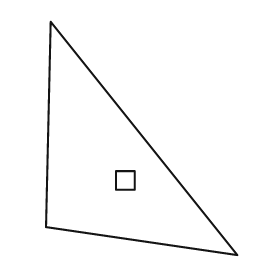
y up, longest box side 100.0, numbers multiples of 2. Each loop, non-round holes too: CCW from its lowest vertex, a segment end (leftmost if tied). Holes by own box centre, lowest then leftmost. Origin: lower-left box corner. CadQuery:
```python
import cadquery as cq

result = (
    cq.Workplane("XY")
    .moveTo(82.0, 0.0)
    .lineTo(2.0, 100.0)
    .lineTo(0.0, 12.0)
    .close()
    .moveTo(30.0, 28.0)
    .lineTo(38.0, 28.0)
    .lineTo(38.0, 36.0)
    .lineTo(30.0, 36.0)
    .close()
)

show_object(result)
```